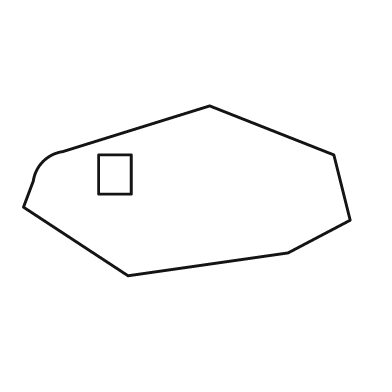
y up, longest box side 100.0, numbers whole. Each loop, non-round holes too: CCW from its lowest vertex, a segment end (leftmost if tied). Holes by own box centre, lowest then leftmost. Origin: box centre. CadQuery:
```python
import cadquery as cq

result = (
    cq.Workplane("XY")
    .moveTo(-18.0, -26.0)
    .lineTo(31.0, -19.0)
    .lineTo(50.0, -9.0)
    .lineTo(45.0, 11.0)
    .lineTo(7.0, 26.0)
    .lineTo(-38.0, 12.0)
    .threePointArc((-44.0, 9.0), (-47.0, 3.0))
    .lineTo(-50.0, -5.0)
    .close()
    .moveTo(-27.0, -1.0)
    .lineTo(-17.0, -1.0)
    .lineTo(-17.0, 11.0)
    .lineTo(-27.0, 11.0)
    .close()
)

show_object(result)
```